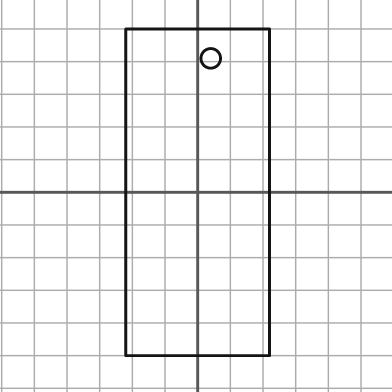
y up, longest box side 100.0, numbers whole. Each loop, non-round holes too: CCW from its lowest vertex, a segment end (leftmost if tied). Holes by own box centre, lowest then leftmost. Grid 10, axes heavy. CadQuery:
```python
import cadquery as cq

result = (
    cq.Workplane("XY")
    .moveTo(-22.0, -50.0)
    .lineTo(22.0, -50.0)
    .lineTo(22.0, 50.0)
    .lineTo(-22.0, 50.0)
    .close()
    .moveTo(4.0, 41.0)
    .circle(3.0)
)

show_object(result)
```